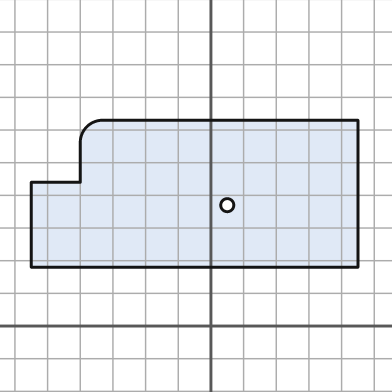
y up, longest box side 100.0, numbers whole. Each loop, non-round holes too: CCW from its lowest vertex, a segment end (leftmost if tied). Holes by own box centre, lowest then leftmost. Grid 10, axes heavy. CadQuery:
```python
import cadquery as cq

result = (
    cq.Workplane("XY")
    .moveTo(-55.0, 18.0)
    .lineTo(45.0, 18.0)
    .lineTo(45.0, 63.0)
    .lineTo(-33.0, 63.0)
    .threePointArc((-38.0, 61.0), (-40.0, 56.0))
    .lineTo(-40.0, 44.0)
    .lineTo(-55.0, 44.0)
    .close()
    .moveTo(5.0, 37.0)
    .circle(2.0)
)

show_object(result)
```